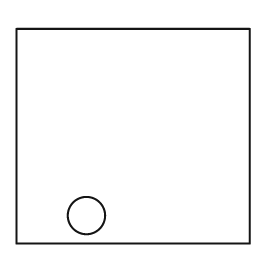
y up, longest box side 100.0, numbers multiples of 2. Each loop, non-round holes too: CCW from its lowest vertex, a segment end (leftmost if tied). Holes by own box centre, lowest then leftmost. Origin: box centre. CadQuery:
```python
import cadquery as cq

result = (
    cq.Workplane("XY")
    .moveTo(-50.0, -46.0)
    .lineTo(50.0, -46.0)
    .lineTo(50.0, 46.0)
    .lineTo(-50.0, 46.0)
    .close()
    .moveTo(-20.0, -34.0)
    .circle(8.0)
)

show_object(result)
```